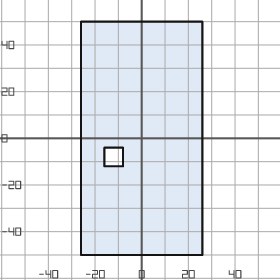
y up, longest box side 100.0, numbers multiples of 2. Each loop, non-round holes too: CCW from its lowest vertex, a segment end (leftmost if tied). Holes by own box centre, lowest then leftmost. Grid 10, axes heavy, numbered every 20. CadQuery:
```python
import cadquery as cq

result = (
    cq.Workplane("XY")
    .moveTo(-26.0, -50.0)
    .lineTo(26.0, -50.0)
    .lineTo(26.0, 50.0)
    .lineTo(-26.0, 50.0)
    .close()
    .moveTo(-16.0, -12.0)
    .lineTo(-8.0, -12.0)
    .lineTo(-8.0, -4.0)
    .lineTo(-16.0, -4.0)
    .close()
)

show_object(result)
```